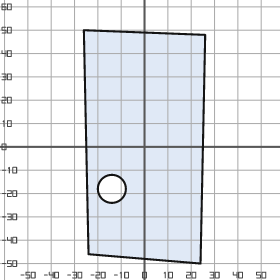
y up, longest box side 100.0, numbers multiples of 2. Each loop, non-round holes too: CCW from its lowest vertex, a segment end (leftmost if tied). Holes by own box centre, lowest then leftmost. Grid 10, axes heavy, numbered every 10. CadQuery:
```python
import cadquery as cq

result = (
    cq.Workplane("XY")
    .moveTo(24.0, -50.0)
    .lineTo(26.0, 48.0)
    .lineTo(-26.0, 50.0)
    .lineTo(-24.0, -46.0)
    .close()
    .moveTo(-14.0, -18.0)
    .circle(6.0)
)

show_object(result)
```